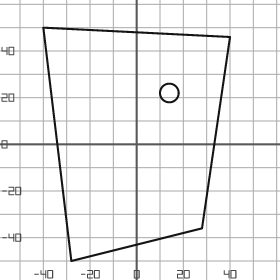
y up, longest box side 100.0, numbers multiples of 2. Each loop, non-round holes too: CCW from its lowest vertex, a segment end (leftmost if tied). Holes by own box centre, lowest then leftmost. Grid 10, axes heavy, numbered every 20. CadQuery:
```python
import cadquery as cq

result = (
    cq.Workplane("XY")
    .moveTo(-28.0, -50.0)
    .lineTo(28.0, -36.0)
    .lineTo(40.0, 46.0)
    .lineTo(-40.0, 50.0)
    .close()
    .moveTo(14.0, 22.0)
    .circle(4.0)
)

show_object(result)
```